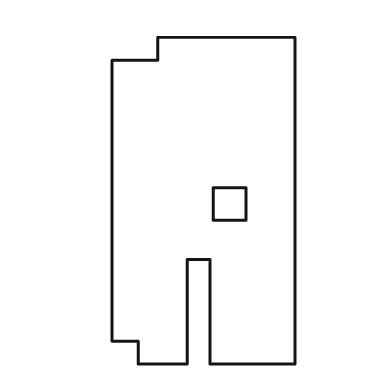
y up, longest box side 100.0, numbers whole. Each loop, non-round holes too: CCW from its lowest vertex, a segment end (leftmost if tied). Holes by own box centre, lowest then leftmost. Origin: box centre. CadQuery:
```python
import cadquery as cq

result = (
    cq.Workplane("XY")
    .moveTo(-20.0, -50.0)
    .lineTo(-5.0, -50.0)
    .lineTo(-5.0, -18.0)
    .lineTo(2.0, -18.0)
    .lineTo(2.0, -50.0)
    .lineTo(28.0, -50.0)
    .lineTo(28.0, 50.0)
    .lineTo(-14.0, 50.0)
    .lineTo(-14.0, 43.0)
    .lineTo(-28.0, 43.0)
    .lineTo(-28.0, -43.0)
    .lineTo(-20.0, -43.0)
    .close()
    .moveTo(3.0, -6.0)
    .lineTo(13.0, -6.0)
    .lineTo(13.0, 4.0)
    .lineTo(3.0, 4.0)
    .close()
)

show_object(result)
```